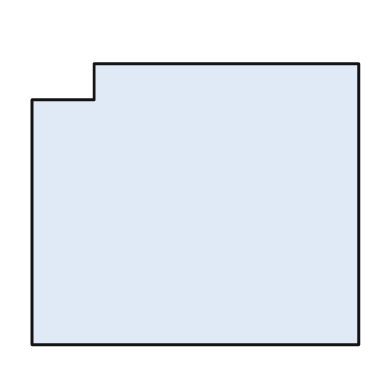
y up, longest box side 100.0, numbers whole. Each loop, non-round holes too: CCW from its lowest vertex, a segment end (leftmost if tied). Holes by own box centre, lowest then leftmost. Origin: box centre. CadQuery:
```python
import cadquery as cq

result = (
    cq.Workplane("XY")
    .moveTo(-50.0, -43.0)
    .lineTo(50.0, -43.0)
    .lineTo(50.0, 43.0)
    .lineTo(-31.0, 43.0)
    .lineTo(-31.0, 32.0)
    .lineTo(-50.0, 32.0)
    .close()
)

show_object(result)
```